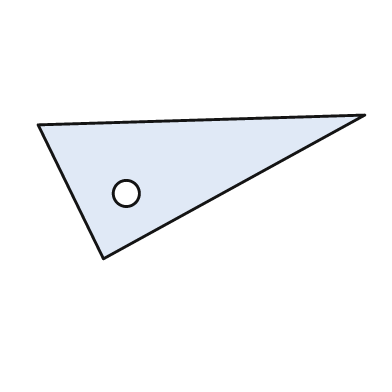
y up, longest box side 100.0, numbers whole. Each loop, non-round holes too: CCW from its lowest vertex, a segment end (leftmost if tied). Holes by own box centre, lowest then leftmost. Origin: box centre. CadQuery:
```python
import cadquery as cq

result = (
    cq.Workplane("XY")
    .moveTo(-30.0, -22.0)
    .lineTo(50.0, 22.0)
    .lineTo(-50.0, 19.0)
    .close()
    .moveTo(-23.0, -2.0)
    .circle(4.0)
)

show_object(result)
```